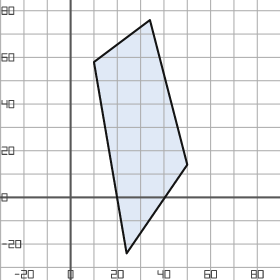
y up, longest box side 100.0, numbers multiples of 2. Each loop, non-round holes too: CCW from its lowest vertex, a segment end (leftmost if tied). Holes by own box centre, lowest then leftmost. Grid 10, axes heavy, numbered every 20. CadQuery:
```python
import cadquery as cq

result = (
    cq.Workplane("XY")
    .moveTo(24.0, -24.0)
    .lineTo(50.0, 14.0)
    .lineTo(34.0, 76.0)
    .lineTo(10.0, 58.0)
    .close()
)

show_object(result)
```